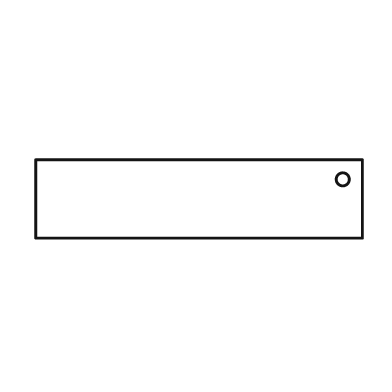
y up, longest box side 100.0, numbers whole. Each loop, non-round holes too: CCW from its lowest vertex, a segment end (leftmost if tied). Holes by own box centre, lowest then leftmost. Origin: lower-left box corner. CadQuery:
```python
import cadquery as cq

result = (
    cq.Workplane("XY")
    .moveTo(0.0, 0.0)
    .lineTo(100.0, 0.0)
    .lineTo(100.0, 24.0)
    .lineTo(0.0, 24.0)
    .close()
    .moveTo(94.0, 18.0)
    .circle(2.0)
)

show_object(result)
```